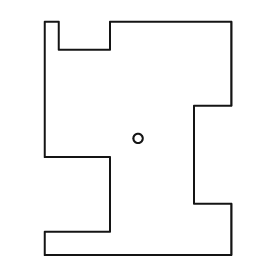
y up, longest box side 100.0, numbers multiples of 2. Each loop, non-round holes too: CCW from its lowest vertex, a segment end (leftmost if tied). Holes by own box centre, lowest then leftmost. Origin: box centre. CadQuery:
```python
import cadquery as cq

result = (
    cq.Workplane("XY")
    .moveTo(-40.0, -50.0)
    .lineTo(40.0, -50.0)
    .lineTo(40.0, -28.0)
    .lineTo(24.0, -28.0)
    .lineTo(24.0, 14.0)
    .lineTo(40.0, 14.0)
    .lineTo(40.0, 50.0)
    .lineTo(-12.0, 50.0)
    .lineTo(-12.0, 38.0)
    .lineTo(-34.0, 38.0)
    .lineTo(-34.0, 50.0)
    .lineTo(-40.0, 50.0)
    .lineTo(-40.0, -8.0)
    .lineTo(-12.0, -8.0)
    .lineTo(-12.0, -40.0)
    .lineTo(-40.0, -40.0)
    .close()
    .moveTo(0.0, 0.0)
    .circle(2.0)
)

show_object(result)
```